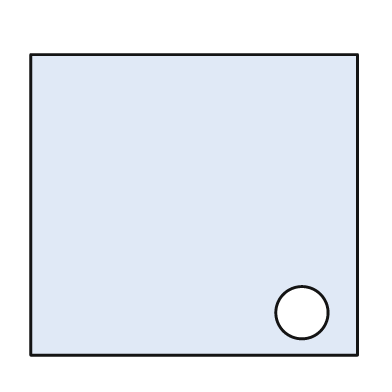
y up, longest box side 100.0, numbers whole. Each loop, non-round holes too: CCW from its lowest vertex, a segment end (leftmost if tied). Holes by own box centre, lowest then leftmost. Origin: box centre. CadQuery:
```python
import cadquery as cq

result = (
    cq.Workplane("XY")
    .moveTo(-50.0, -46.0)
    .lineTo(50.0, -46.0)
    .lineTo(50.0, 46.0)
    .lineTo(-50.0, 46.0)
    .close()
    .moveTo(33.0, -33.0)
    .circle(8.0)
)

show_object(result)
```